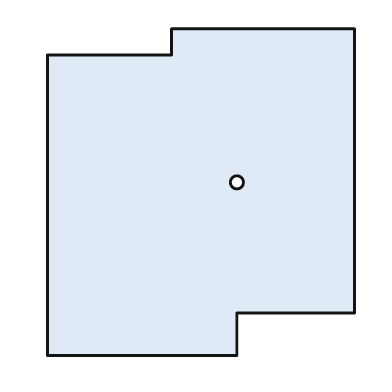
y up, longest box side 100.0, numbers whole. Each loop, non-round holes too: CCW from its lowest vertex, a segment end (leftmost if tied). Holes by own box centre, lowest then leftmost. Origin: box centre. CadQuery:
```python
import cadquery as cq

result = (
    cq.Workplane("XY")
    .moveTo(-47.0, -50.0)
    .lineTo(11.0, -50.0)
    .lineTo(11.0, -37.0)
    .lineTo(47.0, -37.0)
    .lineTo(47.0, 50.0)
    .lineTo(-9.0, 50.0)
    .lineTo(-9.0, 42.0)
    .lineTo(-47.0, 42.0)
    .close()
    .moveTo(11.0, 3.0)
    .circle(2.0)
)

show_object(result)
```